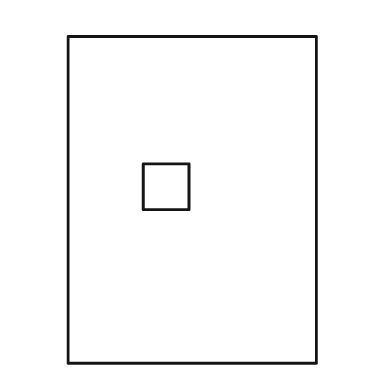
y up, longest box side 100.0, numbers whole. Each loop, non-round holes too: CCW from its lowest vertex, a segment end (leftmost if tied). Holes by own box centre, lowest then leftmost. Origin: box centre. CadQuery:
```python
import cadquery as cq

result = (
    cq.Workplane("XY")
    .moveTo(-38.0, -50.0)
    .lineTo(38.0, -50.0)
    .lineTo(38.0, 50.0)
    .lineTo(-38.0, 50.0)
    .close()
    .moveTo(-15.0, -3.0)
    .lineTo(-1.0, -3.0)
    .lineTo(-1.0, 11.0)
    .lineTo(-15.0, 11.0)
    .close()
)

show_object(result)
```